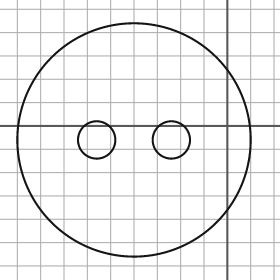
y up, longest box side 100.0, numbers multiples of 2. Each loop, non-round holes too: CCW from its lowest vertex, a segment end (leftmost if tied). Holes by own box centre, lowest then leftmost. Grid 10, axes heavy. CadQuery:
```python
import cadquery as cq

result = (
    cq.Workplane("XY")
    .moveTo(-40.0, -6.0)
    .circle(50.0)
    .moveTo(-56.0, -6.0)
    .circle(8.0)
    .moveTo(-24.0, -6.0)
    .circle(8.0)
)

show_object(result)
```